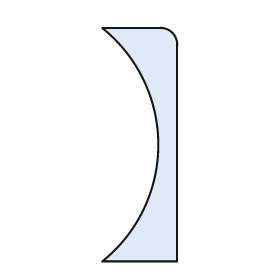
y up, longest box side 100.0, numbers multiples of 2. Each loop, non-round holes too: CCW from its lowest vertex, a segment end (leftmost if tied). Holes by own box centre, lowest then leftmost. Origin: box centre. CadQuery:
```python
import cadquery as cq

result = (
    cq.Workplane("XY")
    .moveTo(-16.0, -50.0)
    .lineTo(16.0, -50.0)
    .lineTo(16.0, 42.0)
    .threePointArc((14.0, 48.0), (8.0, 50.0))
    .lineTo(-16.0, 50.0)
    .threePointArc((8.0, 0.0), (-16.0, -50.0))
    .close()
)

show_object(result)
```